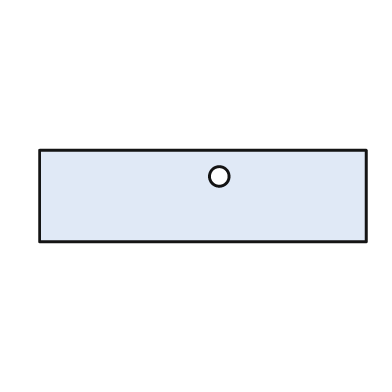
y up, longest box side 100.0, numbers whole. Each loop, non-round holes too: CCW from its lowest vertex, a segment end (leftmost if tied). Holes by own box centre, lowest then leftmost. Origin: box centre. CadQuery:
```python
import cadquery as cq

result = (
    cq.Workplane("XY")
    .moveTo(-50.0, -14.0)
    .lineTo(50.0, -14.0)
    .lineTo(50.0, 14.0)
    .lineTo(-50.0, 14.0)
    .close()
    .moveTo(5.0, 6.0)
    .circle(3.0)
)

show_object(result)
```